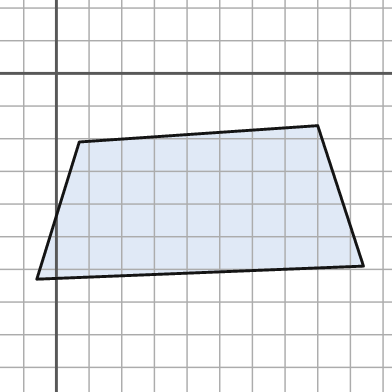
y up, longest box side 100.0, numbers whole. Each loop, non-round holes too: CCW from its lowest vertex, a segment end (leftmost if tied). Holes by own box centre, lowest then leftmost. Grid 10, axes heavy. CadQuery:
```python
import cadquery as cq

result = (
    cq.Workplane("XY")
    .moveTo(-6.0, -63.0)
    .lineTo(94.0, -59.0)
    .lineTo(80.0, -16.0)
    .lineTo(7.0, -21.0)
    .close()
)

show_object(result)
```